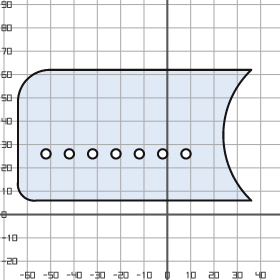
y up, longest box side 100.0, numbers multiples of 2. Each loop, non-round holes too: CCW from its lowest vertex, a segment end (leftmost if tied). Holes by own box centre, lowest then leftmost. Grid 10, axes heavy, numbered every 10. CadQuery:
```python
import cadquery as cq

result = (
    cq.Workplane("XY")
    .moveTo(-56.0, 6.0)
    .lineTo(36.0, 6.0)
    .threePointArc((24.0, 34.0), (36.0, 62.0))
    .lineTo(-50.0, 62.0)
    .threePointArc((-60.0, 58.0), (-64.0, 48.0))
    .lineTo(-64.0, 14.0)
    .threePointArc((-62.0, 8.0), (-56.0, 6.0))
    .close()
    .moveTo(-52.0, 26.0)
    .circle(2.0)
    .moveTo(-42.0, 26.0)
    .circle(2.0)
    .moveTo(-32.0, 26.0)
    .circle(2.0)
    .moveTo(-22.0, 26.0)
    .circle(2.0)
    .moveTo(-12.0, 26.0)
    .circle(2.0)
    .moveTo(-2.0, 26.0)
    .circle(2.0)
    .moveTo(8.0, 26.0)
    .circle(2.0)
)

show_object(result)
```